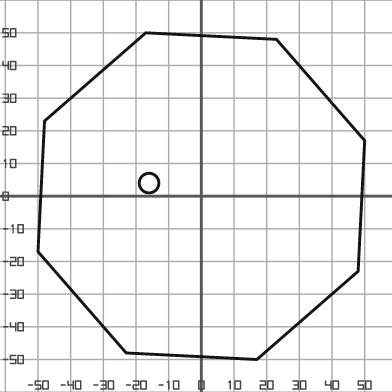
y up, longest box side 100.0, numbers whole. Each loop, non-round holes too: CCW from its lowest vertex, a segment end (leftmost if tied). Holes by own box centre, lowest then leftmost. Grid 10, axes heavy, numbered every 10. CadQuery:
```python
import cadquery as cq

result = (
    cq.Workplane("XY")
    .moveTo(17.0, -50.0)
    .lineTo(48.0, -23.0)
    .lineTo(50.0, 17.0)
    .lineTo(23.0, 48.0)
    .lineTo(-17.0, 50.0)
    .lineTo(-48.0, 23.0)
    .lineTo(-50.0, -17.0)
    .lineTo(-23.0, -48.0)
    .close()
    .moveTo(-16.0, 4.0)
    .circle(3.0)
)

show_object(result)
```